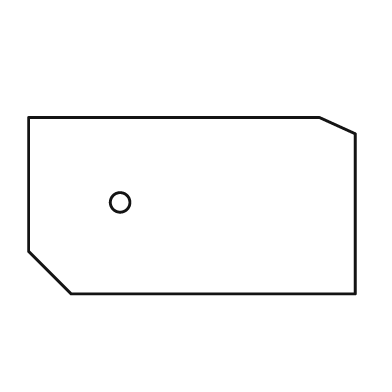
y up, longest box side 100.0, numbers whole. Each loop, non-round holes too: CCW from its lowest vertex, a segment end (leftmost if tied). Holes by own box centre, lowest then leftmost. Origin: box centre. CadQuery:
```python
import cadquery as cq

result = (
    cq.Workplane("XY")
    .moveTo(-37.0, -27.0)
    .lineTo(50.0, -27.0)
    .lineTo(50.0, 22.0)
    .lineTo(39.0, 27.0)
    .lineTo(-50.0, 27.0)
    .lineTo(-50.0, -14.0)
    .close()
    .moveTo(-22.0, 1.0)
    .circle(3.0)
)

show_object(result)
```